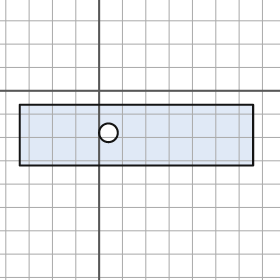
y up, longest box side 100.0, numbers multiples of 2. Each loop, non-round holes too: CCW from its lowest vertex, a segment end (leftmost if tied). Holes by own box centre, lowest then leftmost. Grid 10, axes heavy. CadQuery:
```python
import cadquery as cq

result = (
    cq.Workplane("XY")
    .moveTo(-34.0, -32.0)
    .lineTo(66.0, -32.0)
    .lineTo(66.0, -6.0)
    .lineTo(-34.0, -6.0)
    .close()
    .moveTo(4.0, -18.0)
    .circle(4.0)
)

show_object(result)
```